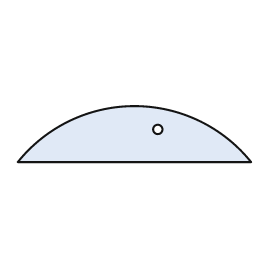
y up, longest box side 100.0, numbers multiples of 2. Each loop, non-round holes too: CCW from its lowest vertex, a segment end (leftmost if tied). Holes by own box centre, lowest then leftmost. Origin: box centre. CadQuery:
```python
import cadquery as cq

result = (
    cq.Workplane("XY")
    .moveTo(-50.0, -12.0)
    .lineTo(50.0, -12.0)
    .threePointArc((0.0, 12.0), (-50.0, -12.0))
    .close()
    .moveTo(10.0, 2.0)
    .circle(2.0)
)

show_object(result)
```